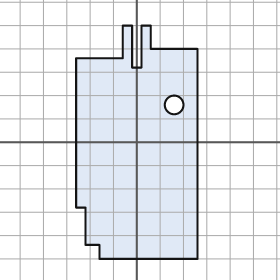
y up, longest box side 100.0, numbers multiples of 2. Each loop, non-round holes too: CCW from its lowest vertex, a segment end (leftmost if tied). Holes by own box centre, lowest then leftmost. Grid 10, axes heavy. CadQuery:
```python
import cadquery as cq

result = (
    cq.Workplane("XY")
    .moveTo(-16.0, -50.0)
    .lineTo(26.0, -50.0)
    .lineTo(26.0, 40.0)
    .lineTo(6.0, 40.0)
    .lineTo(6.0, 50.0)
    .lineTo(2.0, 50.0)
    .lineTo(2.0, 32.0)
    .lineTo(-2.0, 32.0)
    .lineTo(-2.0, 50.0)
    .lineTo(-6.0, 50.0)
    .lineTo(-6.0, 36.0)
    .lineTo(-26.0, 36.0)
    .lineTo(-26.0, -28.0)
    .lineTo(-22.0, -28.0)
    .lineTo(-22.0, -44.0)
    .lineTo(-16.0, -44.0)
    .close()
    .moveTo(16.0, 16.0)
    .circle(4.0)
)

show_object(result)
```